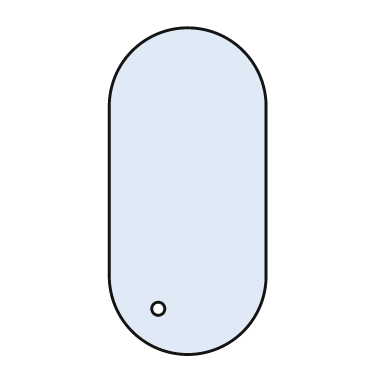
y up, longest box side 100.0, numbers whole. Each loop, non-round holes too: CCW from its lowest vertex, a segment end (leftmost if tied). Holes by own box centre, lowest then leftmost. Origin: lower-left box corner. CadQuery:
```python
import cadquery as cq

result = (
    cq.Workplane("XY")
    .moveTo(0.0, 24.0)
    .threePointArc((24.0, 0.0), (48.0, 24.0))
    .lineTo(48.0, 76.0)
    .threePointArc((24.0, 100.0), (0.0, 76.0))
    .close()
    .moveTo(15.0, 14.0)
    .circle(2.0)
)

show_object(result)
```